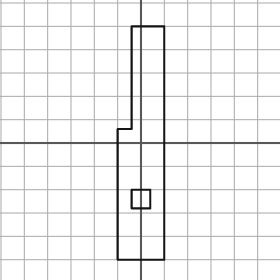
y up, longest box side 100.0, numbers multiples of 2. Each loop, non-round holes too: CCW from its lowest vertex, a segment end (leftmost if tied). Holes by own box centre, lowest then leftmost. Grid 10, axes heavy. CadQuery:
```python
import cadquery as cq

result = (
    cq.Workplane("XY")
    .moveTo(-10.0, -50.0)
    .lineTo(10.0, -50.0)
    .lineTo(10.0, 50.0)
    .lineTo(-4.0, 50.0)
    .lineTo(-4.0, 6.0)
    .lineTo(-10.0, 6.0)
    .close()
    .moveTo(-4.0, -28.0)
    .lineTo(4.0, -28.0)
    .lineTo(4.0, -20.0)
    .lineTo(-4.0, -20.0)
    .close()
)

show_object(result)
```